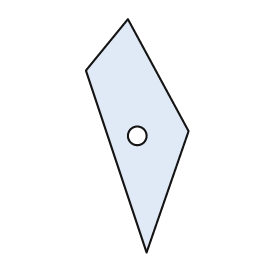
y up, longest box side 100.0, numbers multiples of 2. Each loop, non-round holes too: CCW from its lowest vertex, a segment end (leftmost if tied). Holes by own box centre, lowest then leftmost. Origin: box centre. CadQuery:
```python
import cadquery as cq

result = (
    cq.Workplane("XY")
    .moveTo(4.0, -50.0)
    .lineTo(22.0, 2.0)
    .lineTo(-4.0, 50.0)
    .lineTo(-22.0, 28.0)
    .close()
    .moveTo(0.0, 0.0)
    .circle(4.0)
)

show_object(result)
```